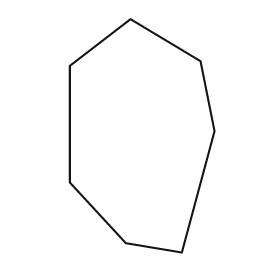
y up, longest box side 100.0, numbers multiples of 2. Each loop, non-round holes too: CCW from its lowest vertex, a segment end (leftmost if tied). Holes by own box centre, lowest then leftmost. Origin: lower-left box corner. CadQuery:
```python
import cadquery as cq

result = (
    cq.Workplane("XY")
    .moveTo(48.0, 0.0)
    .lineTo(62.0, 52.0)
    .lineTo(56.0, 82.0)
    .lineTo(26.0, 100.0)
    .lineTo(0.0, 80.0)
    .lineTo(0.0, 30.0)
    .lineTo(24.0, 4.0)
    .close()
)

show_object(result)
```